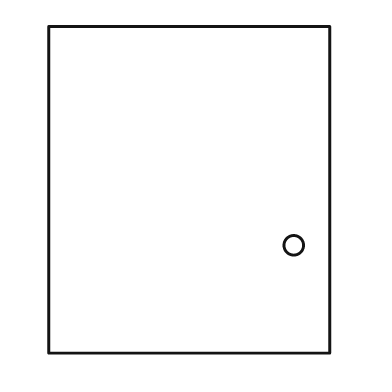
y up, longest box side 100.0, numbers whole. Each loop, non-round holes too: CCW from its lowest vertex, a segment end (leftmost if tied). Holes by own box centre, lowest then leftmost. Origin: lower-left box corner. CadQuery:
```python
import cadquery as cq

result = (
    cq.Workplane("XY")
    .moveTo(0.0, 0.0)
    .lineTo(86.0, 0.0)
    .lineTo(86.0, 100.0)
    .lineTo(0.0, 100.0)
    .close()
    .moveTo(75.0, 33.0)
    .circle(3.0)
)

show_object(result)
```